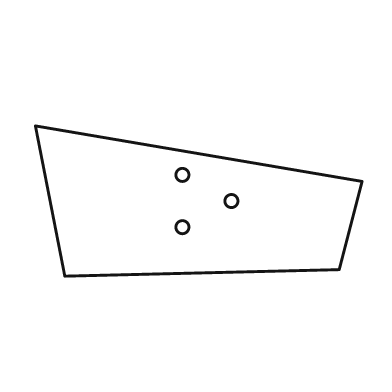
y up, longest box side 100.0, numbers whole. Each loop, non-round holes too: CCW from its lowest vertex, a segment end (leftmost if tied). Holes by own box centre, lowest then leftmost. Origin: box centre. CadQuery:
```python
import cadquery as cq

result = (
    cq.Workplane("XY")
    .moveTo(-41.0, -23.0)
    .lineTo(43.0, -21.0)
    .lineTo(50.0, 6.0)
    .lineTo(-50.0, 23.0)
    .close()
    .moveTo(-5.0, -8.0)
    .circle(2.0)
    .moveTo(10.0, 0.0)
    .circle(2.0)
    .moveTo(-5.0, 8.0)
    .circle(2.0)
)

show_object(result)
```